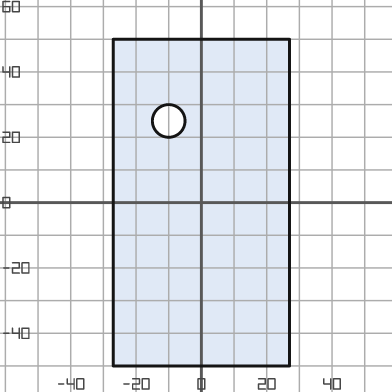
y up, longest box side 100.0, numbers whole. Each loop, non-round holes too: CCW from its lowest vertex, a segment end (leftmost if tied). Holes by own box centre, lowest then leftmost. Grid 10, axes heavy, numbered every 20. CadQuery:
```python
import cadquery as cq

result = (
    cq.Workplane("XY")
    .moveTo(-27.0, -50.0)
    .lineTo(27.0, -50.0)
    .lineTo(27.0, 50.0)
    .lineTo(-27.0, 50.0)
    .close()
    .moveTo(-10.0, 25.0)
    .circle(5.0)
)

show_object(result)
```